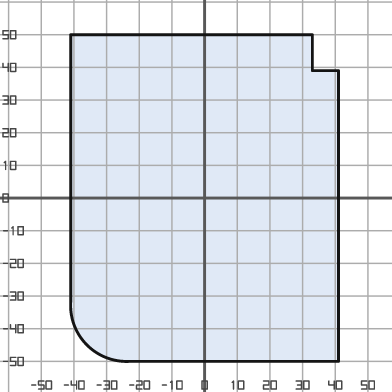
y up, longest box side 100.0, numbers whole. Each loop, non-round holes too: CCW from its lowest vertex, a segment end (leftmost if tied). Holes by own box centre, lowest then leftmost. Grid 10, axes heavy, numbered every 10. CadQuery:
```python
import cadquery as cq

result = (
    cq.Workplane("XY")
    .moveTo(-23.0, -50.0)
    .lineTo(41.0, -50.0)
    .lineTo(41.0, 39.0)
    .lineTo(33.0, 39.0)
    .lineTo(33.0, 50.0)
    .lineTo(-41.0, 50.0)
    .lineTo(-41.0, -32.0)
    .threePointArc((-36.0, -45.0), (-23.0, -50.0))
    .close()
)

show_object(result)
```